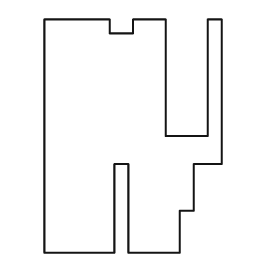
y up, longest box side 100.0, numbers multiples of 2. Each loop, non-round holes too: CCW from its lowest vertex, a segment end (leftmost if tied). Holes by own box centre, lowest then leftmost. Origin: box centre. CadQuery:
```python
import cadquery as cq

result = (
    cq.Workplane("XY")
    .moveTo(-38.0, -50.0)
    .lineTo(-8.0, -50.0)
    .lineTo(-8.0, -12.0)
    .lineTo(-2.0, -12.0)
    .lineTo(-2.0, -50.0)
    .lineTo(20.0, -50.0)
    .lineTo(20.0, -32.0)
    .lineTo(26.0, -32.0)
    .lineTo(26.0, -12.0)
    .lineTo(38.0, -12.0)
    .lineTo(38.0, 50.0)
    .lineTo(32.0, 50.0)
    .lineTo(32.0, 0.0)
    .lineTo(14.0, 0.0)
    .lineTo(14.0, 50.0)
    .lineTo(0.0, 50.0)
    .lineTo(0.0, 44.0)
    .lineTo(-10.0, 44.0)
    .lineTo(-10.0, 50.0)
    .lineTo(-38.0, 50.0)
    .close()
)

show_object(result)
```